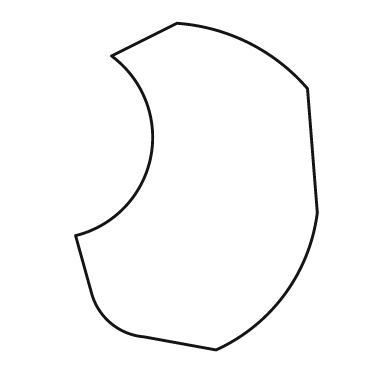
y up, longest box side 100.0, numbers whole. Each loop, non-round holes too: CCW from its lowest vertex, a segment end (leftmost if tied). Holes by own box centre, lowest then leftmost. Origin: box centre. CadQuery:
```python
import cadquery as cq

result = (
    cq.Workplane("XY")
    .moveTo(6.0, -50.0)
    .threePointArc((27.0, -33.0), (37.0, -8.0))
    .lineTo(34.0, 30.0)
    .threePointArc((16.0, 44.0), (-6.0, 50.0))
    .lineTo(-26.0, 40.0)
    .threePointArc((-14.0, 9.0), (-37.0, -15.0))
    .lineTo(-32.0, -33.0)
    .threePointArc((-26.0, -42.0), (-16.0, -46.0))
    .close()
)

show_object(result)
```